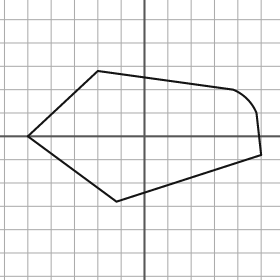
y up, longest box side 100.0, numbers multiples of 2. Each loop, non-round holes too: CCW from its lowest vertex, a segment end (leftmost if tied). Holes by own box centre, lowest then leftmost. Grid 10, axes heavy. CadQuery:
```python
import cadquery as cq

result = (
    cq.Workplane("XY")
    .moveTo(-12.0, -28.0)
    .lineTo(50.0, -8.0)
    .lineTo(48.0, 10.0)
    .threePointArc((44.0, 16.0), (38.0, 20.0))
    .lineTo(-20.0, 28.0)
    .lineTo(-50.0, 0.0)
    .close()
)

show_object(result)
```